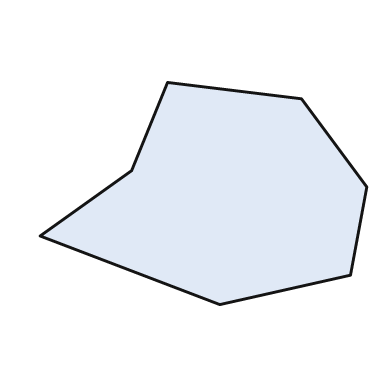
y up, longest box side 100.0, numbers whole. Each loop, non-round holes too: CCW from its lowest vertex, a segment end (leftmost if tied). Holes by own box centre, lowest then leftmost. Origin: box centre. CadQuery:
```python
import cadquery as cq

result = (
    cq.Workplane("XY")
    .moveTo(5.0, -34.0)
    .lineTo(45.0, -25.0)
    .lineTo(50.0, 2.0)
    .lineTo(30.0, 29.0)
    .lineTo(-11.0, 34.0)
    .lineTo(-22.0, 7.0)
    .lineTo(-50.0, -13.0)
    .close()
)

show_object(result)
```